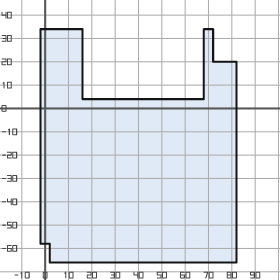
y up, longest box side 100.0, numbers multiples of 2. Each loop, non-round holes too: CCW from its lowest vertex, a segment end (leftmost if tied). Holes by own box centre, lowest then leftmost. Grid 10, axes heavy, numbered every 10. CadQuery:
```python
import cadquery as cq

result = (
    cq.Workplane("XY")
    .moveTo(2.0, -66.0)
    .lineTo(82.0, -66.0)
    .lineTo(82.0, 20.0)
    .lineTo(72.0, 20.0)
    .lineTo(72.0, 34.0)
    .lineTo(68.0, 34.0)
    .lineTo(68.0, 4.0)
    .lineTo(16.0, 4.0)
    .lineTo(16.0, 34.0)
    .lineTo(-2.0, 34.0)
    .lineTo(-2.0, -58.0)
    .lineTo(2.0, -58.0)
    .close()
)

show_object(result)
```